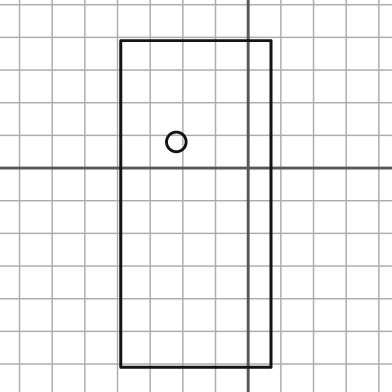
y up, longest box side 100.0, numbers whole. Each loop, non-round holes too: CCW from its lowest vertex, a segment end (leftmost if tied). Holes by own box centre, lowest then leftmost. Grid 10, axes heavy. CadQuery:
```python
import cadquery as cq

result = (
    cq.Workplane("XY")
    .moveTo(-39.0, -61.0)
    .lineTo(7.0, -61.0)
    .lineTo(7.0, 39.0)
    .lineTo(-39.0, 39.0)
    .close()
    .moveTo(-22.0, 8.0)
    .circle(3.0)
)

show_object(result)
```